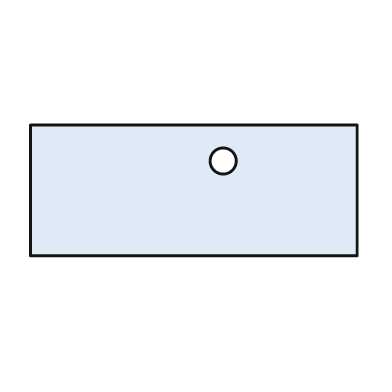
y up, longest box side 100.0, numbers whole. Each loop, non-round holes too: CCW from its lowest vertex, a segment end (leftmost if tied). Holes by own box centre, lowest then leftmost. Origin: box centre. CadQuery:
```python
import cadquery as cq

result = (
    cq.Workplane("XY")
    .moveTo(-50.0, -20.0)
    .lineTo(50.0, -20.0)
    .lineTo(50.0, 20.0)
    .lineTo(-50.0, 20.0)
    .close()
    .moveTo(9.0, 9.0)
    .circle(4.0)
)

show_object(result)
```